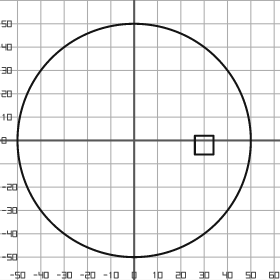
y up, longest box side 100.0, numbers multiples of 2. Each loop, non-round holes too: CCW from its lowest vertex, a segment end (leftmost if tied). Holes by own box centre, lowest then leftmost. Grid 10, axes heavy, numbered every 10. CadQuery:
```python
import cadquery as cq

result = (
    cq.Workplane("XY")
    .moveTo(0.0, 0.0)
    .circle(50.0)
    .moveTo(26.0, -6.0)
    .lineTo(34.0, -6.0)
    .lineTo(34.0, 2.0)
    .lineTo(26.0, 2.0)
    .close()
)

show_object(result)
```